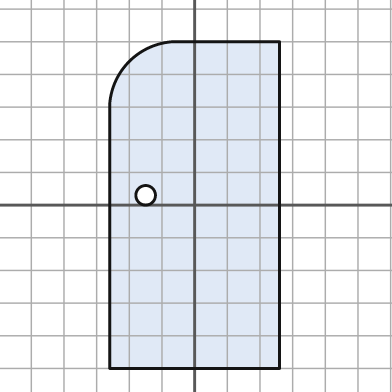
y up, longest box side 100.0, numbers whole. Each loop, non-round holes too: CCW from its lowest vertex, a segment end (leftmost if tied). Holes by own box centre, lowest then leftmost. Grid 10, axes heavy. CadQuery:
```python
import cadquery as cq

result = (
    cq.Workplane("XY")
    .moveTo(-26.0, -50.0)
    .lineTo(26.0, -50.0)
    .lineTo(26.0, 50.0)
    .lineTo(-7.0, 50.0)
    .threePointArc((-20.0, 44.0), (-26.0, 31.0))
    .close()
    .moveTo(-15.0, 3.0)
    .circle(3.0)
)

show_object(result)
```